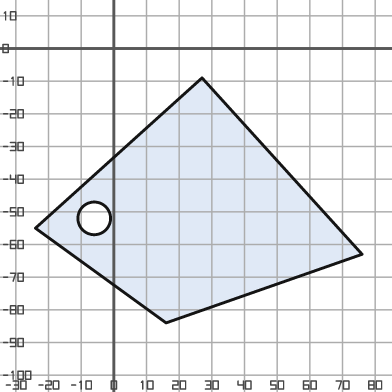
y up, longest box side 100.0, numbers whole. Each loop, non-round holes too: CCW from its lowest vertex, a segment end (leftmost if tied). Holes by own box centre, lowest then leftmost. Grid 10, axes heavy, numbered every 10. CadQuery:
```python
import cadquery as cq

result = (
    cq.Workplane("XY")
    .moveTo(16.0, -84.0)
    .lineTo(76.0, -63.0)
    .lineTo(27.0, -9.0)
    .lineTo(-24.0, -55.0)
    .close()
    .moveTo(-6.0, -52.0)
    .circle(5.0)
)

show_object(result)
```